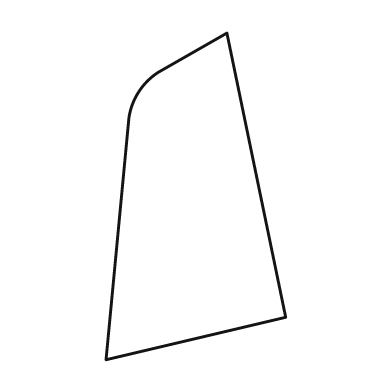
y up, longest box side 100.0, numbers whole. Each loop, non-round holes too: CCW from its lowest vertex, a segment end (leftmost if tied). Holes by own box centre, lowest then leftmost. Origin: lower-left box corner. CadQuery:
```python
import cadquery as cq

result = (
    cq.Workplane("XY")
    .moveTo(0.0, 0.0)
    .lineTo(55.0, 13.0)
    .lineTo(37.0, 100.0)
    .lineTo(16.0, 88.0)
    .threePointArc((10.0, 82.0), (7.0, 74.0))
    .close()
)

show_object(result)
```